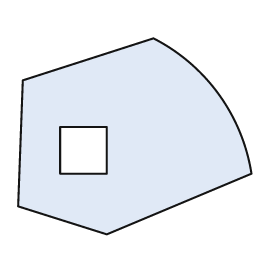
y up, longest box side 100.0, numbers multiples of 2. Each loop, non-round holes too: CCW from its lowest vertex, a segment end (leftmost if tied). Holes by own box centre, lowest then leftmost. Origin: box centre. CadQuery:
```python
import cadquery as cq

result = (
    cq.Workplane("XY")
    .moveTo(-12.0, -42.0)
    .lineTo(50.0, -16.0)
    .threePointArc((36.0, 18.0), (8.0, 42.0))
    .lineTo(-48.0, 24.0)
    .lineTo(-50.0, -30.0)
    .close()
    .moveTo(-32.0, -16.0)
    .lineTo(-12.0, -16.0)
    .lineTo(-12.0, 4.0)
    .lineTo(-32.0, 4.0)
    .close()
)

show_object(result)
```